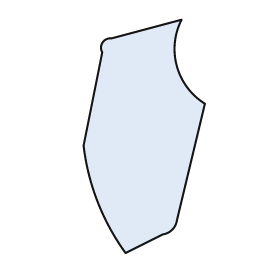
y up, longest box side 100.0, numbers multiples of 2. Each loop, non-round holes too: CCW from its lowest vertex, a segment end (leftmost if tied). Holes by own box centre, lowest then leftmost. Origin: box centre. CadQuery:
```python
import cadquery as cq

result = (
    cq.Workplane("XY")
    .moveTo(-8.0, -50.0)
    .lineTo(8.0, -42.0)
    .threePointArc((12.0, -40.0), (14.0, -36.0))
    .lineTo(26.0, 14.0)
    .threePointArc((14.0, 30.0), (16.0, 50.0))
    .lineTo(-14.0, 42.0)
    .threePointArc((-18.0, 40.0), (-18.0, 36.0))
    .lineTo(-26.0, -4.0)
    .threePointArc((-20.0, -28.0), (-8.0, -50.0))
    .close()
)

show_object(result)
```